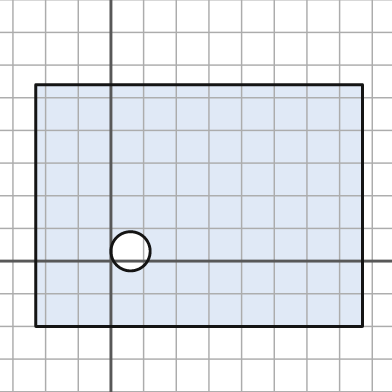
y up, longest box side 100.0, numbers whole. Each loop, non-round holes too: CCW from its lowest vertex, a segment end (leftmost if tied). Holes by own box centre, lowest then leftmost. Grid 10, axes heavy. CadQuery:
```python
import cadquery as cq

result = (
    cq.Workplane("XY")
    .moveTo(-23.0, -20.0)
    .lineTo(77.0, -20.0)
    .lineTo(77.0, 54.0)
    .lineTo(-23.0, 54.0)
    .close()
    .moveTo(6.0, 3.0)
    .circle(6.0)
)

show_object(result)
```